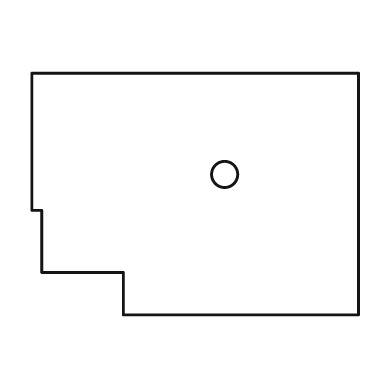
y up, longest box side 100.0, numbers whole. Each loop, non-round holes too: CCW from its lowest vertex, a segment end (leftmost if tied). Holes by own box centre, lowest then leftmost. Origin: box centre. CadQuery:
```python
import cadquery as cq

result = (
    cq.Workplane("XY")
    .moveTo(-22.0, -37.0)
    .lineTo(50.0, -37.0)
    .lineTo(50.0, 37.0)
    .lineTo(-50.0, 37.0)
    .lineTo(-50.0, -5.0)
    .lineTo(-47.0, -5.0)
    .lineTo(-47.0, -24.0)
    .lineTo(-22.0, -24.0)
    .close()
    .moveTo(9.0, 6.0)
    .circle(4.0)
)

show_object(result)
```